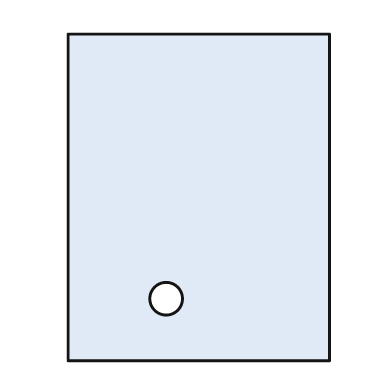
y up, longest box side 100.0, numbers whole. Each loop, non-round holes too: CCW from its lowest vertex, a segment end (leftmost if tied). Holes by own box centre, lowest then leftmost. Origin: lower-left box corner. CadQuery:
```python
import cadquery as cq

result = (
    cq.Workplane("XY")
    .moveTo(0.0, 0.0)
    .lineTo(80.0, 0.0)
    .lineTo(80.0, 100.0)
    .lineTo(0.0, 100.0)
    .close()
    .moveTo(30.0, 19.0)
    .circle(5.0)
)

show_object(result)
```